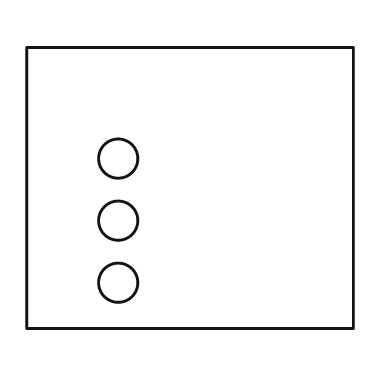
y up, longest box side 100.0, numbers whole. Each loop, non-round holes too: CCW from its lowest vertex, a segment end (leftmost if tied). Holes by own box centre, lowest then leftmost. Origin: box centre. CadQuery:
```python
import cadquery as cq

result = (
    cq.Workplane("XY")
    .moveTo(-50.0, -43.0)
    .lineTo(50.0, -43.0)
    .lineTo(50.0, 43.0)
    .lineTo(-50.0, 43.0)
    .close()
    .moveTo(-22.0, -29.0)
    .circle(6.0)
    .moveTo(-22.0, -10.0)
    .circle(6.0)
    .moveTo(-22.0, 9.0)
    .circle(6.0)
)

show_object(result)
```